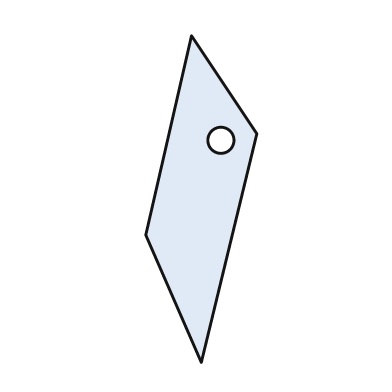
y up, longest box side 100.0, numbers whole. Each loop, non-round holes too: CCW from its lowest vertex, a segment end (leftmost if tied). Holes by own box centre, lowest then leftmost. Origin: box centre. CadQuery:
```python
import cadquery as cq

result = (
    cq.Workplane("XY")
    .moveTo(0.0, -50.0)
    .lineTo(17.0, 20.0)
    .lineTo(-3.0, 50.0)
    .lineTo(-17.0, -11.0)
    .close()
    .moveTo(6.0, 18.0)
    .circle(4.0)
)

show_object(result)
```